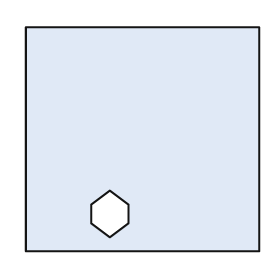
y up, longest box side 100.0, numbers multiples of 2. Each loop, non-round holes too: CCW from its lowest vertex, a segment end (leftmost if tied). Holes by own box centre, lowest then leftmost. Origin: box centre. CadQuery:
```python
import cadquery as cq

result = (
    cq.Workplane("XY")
    .moveTo(-50.0, -48.0)
    .lineTo(50.0, -48.0)
    .lineTo(50.0, 48.0)
    .lineTo(-50.0, 48.0)
    .close()
    .moveTo(-14.0, -42.0)
    .lineTo(-6.0, -36.0)
    .lineTo(-6.0, -28.0)
    .lineTo(-14.0, -22.0)
    .lineTo(-22.0, -28.0)
    .lineTo(-22.0, -36.0)
    .close()
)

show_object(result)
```